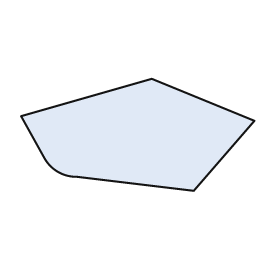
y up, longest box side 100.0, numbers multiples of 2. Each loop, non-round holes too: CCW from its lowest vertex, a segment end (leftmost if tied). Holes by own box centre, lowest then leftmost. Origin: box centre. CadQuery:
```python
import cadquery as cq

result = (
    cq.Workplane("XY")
    .moveTo(24.0, -24.0)
    .lineTo(50.0, 6.0)
    .lineTo(6.0, 24.0)
    .lineTo(-50.0, 8.0)
    .lineTo(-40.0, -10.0)
    .threePointArc((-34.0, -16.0), (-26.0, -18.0))
    .close()
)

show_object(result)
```